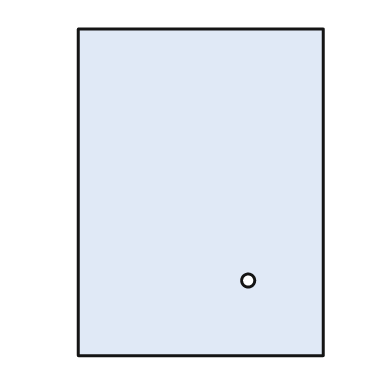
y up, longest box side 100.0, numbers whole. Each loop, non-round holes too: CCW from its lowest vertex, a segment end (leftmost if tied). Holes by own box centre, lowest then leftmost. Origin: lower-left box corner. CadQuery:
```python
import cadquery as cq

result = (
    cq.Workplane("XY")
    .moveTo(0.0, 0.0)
    .lineTo(75.0, 0.0)
    .lineTo(75.0, 100.0)
    .lineTo(0.0, 100.0)
    .close()
    .moveTo(52.0, 23.0)
    .circle(2.0)
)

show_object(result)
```